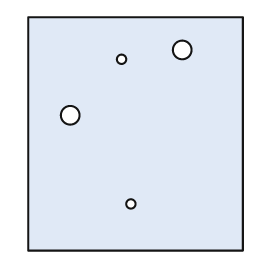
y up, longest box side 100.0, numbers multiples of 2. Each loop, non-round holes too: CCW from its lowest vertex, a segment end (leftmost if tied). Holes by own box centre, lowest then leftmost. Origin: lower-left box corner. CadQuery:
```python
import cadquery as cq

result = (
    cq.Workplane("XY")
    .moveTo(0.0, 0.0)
    .lineTo(92.0, 0.0)
    .lineTo(92.0, 100.0)
    .lineTo(0.0, 100.0)
    .close()
    .moveTo(44.0, 20.0)
    .circle(2.0)
    .moveTo(18.0, 58.0)
    .circle(4.0)
    .moveTo(40.0, 82.0)
    .circle(2.0)
    .moveTo(66.0, 86.0)
    .circle(4.0)
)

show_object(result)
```